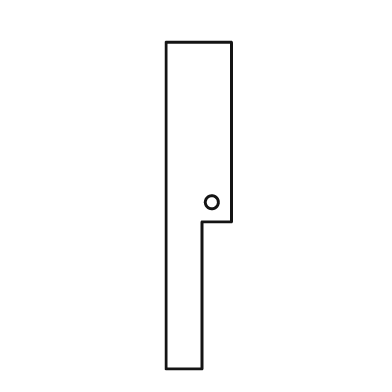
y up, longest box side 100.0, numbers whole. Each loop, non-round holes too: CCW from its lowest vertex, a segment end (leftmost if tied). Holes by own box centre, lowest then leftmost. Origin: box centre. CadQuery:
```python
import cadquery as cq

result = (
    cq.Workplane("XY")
    .moveTo(-10.0, -50.0)
    .lineTo(1.0, -50.0)
    .lineTo(1.0, -5.0)
    .lineTo(10.0, -5.0)
    .lineTo(10.0, 50.0)
    .lineTo(-10.0, 50.0)
    .close()
    .moveTo(4.0, 1.0)
    .circle(2.0)
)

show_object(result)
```